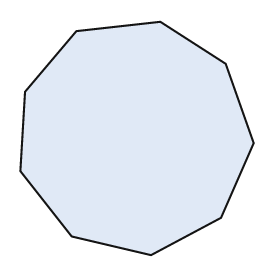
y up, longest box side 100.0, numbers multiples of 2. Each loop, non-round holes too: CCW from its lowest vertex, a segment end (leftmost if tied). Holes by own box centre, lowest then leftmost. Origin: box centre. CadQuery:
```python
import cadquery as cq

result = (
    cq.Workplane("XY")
    .moveTo(6.0, -50.0)
    .lineTo(36.0, -34.0)
    .lineTo(50.0, -2.0)
    .lineTo(38.0, 32.0)
    .lineTo(10.0, 50.0)
    .lineTo(-26.0, 46.0)
    .lineTo(-48.0, 20.0)
    .lineTo(-50.0, -14.0)
    .lineTo(-28.0, -42.0)
    .close()
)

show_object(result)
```